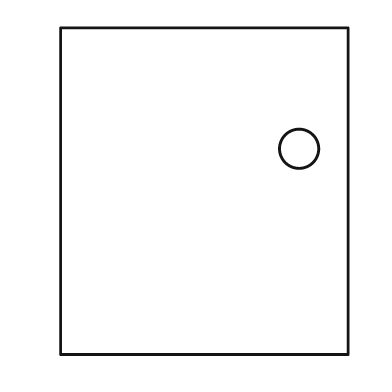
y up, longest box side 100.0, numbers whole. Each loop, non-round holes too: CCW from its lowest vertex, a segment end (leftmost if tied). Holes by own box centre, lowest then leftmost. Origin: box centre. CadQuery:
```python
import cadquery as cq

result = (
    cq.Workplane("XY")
    .moveTo(-44.0, -50.0)
    .lineTo(44.0, -50.0)
    .lineTo(44.0, 50.0)
    .lineTo(-44.0, 50.0)
    .close()
    .moveTo(29.0, 13.0)
    .circle(6.0)
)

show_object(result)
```